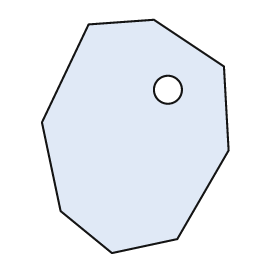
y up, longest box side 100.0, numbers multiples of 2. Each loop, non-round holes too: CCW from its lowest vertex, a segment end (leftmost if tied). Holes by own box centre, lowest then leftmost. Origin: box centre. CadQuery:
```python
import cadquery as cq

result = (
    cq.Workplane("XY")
    .moveTo(-10.0, -50.0)
    .lineTo(18.0, -44.0)
    .lineTo(40.0, -6.0)
    .lineTo(38.0, 30.0)
    .lineTo(8.0, 50.0)
    .lineTo(-20.0, 48.0)
    .lineTo(-40.0, 6.0)
    .lineTo(-32.0, -32.0)
    .close()
    .moveTo(14.0, 20.0)
    .circle(6.0)
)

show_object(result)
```